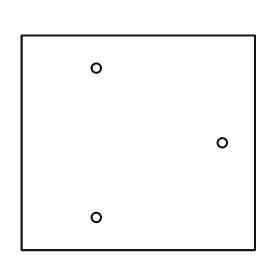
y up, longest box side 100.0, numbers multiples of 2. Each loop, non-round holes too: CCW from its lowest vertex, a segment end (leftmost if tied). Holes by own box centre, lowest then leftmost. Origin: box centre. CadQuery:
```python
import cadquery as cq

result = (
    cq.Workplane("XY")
    .moveTo(-50.0, -46.0)
    .lineTo(50.0, -46.0)
    .lineTo(50.0, 46.0)
    .lineTo(-50.0, 46.0)
    .close()
    .moveTo(-18.0, -32.0)
    .circle(2.0)
    .moveTo(36.0, 0.0)
    .circle(2.0)
    .moveTo(-18.0, 32.0)
    .circle(2.0)
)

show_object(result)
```